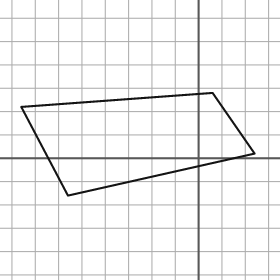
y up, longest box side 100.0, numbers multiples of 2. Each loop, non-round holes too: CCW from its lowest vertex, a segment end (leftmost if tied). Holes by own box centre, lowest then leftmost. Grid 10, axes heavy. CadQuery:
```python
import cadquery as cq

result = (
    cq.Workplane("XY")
    .moveTo(-56.0, -16.0)
    .lineTo(24.0, 2.0)
    .lineTo(6.0, 28.0)
    .lineTo(-76.0, 22.0)
    .close()
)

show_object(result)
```